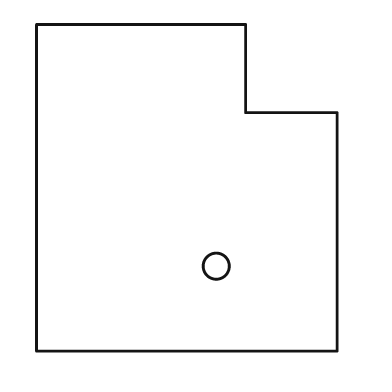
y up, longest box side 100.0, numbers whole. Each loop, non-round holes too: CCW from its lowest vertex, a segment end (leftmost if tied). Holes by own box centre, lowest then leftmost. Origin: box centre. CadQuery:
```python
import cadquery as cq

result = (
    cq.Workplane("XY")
    .moveTo(-46.0, -50.0)
    .lineTo(46.0, -50.0)
    .lineTo(46.0, 23.0)
    .lineTo(18.0, 23.0)
    .lineTo(18.0, 50.0)
    .lineTo(-46.0, 50.0)
    .close()
    .moveTo(9.0, -24.0)
    .circle(4.0)
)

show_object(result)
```